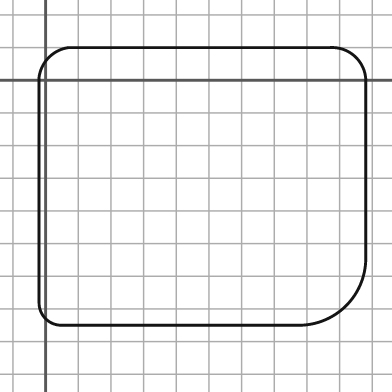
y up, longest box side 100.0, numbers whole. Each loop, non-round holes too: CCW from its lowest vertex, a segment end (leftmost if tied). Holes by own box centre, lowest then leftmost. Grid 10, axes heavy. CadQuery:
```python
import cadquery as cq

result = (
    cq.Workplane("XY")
    .moveTo(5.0, -75.0)
    .lineTo(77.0, -75.0)
    .threePointArc((92.0, -69.0), (98.0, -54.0))
    .lineTo(98.0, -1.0)
    .threePointArc((95.0, 7.0), (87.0, 10.0))
    .lineTo(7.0, 10.0)
    .threePointArc((1.0, 7.0), (-2.0, 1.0))
    .lineTo(-2.0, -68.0)
    .threePointArc((0.0, -73.0), (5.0, -75.0))
    .close()
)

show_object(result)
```